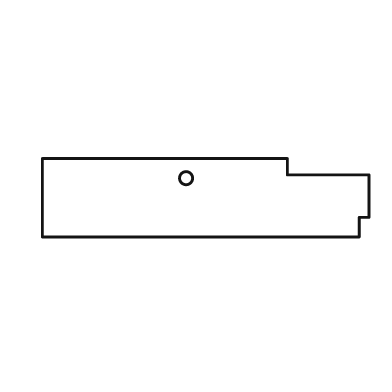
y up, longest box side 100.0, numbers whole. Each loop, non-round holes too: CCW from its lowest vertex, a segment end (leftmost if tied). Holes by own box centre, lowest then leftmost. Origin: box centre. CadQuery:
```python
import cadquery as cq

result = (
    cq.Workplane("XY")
    .moveTo(-50.0, -12.0)
    .lineTo(47.0, -12.0)
    .lineTo(47.0, -6.0)
    .lineTo(50.0, -6.0)
    .lineTo(50.0, 7.0)
    .lineTo(25.0, 7.0)
    .lineTo(25.0, 12.0)
    .lineTo(-50.0, 12.0)
    .close()
    .moveTo(-6.0, 6.0)
    .circle(2.0)
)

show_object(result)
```